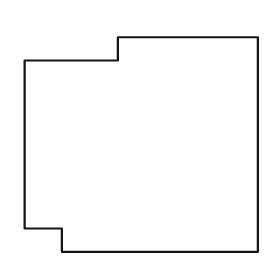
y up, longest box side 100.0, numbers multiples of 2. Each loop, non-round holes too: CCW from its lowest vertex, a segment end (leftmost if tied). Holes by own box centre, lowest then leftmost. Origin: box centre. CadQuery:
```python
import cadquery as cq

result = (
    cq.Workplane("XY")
    .moveTo(-34.0, -46.0)
    .lineTo(50.0, -46.0)
    .lineTo(50.0, 46.0)
    .lineTo(-10.0, 46.0)
    .lineTo(-10.0, 36.0)
    .lineTo(-50.0, 36.0)
    .lineTo(-50.0, -36.0)
    .lineTo(-34.0, -36.0)
    .close()
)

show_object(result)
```